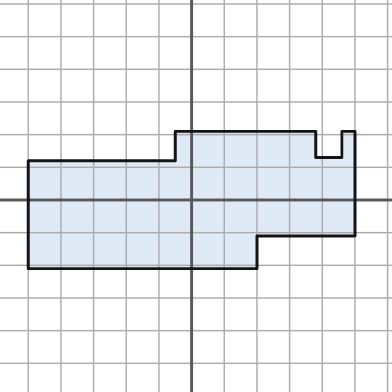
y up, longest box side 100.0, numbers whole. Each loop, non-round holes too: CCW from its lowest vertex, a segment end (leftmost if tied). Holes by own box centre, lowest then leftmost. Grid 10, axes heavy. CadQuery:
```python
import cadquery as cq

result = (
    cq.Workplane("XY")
    .moveTo(-50.0, -21.0)
    .lineTo(20.0, -21.0)
    .lineTo(20.0, -11.0)
    .lineTo(50.0, -11.0)
    .lineTo(50.0, 21.0)
    .lineTo(46.0, 21.0)
    .lineTo(46.0, 13.0)
    .lineTo(38.0, 13.0)
    .lineTo(38.0, 21.0)
    .lineTo(-5.0, 21.0)
    .lineTo(-5.0, 12.0)
    .lineTo(-50.0, 12.0)
    .close()
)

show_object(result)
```